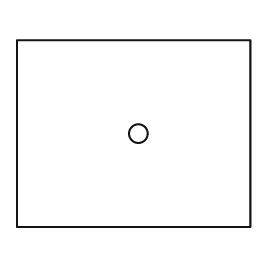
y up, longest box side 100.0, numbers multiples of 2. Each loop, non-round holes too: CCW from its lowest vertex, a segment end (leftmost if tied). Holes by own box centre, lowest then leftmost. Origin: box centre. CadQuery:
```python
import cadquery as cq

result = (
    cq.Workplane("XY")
    .moveTo(-50.0, -40.0)
    .lineTo(50.0, -40.0)
    .lineTo(50.0, 40.0)
    .lineTo(-50.0, 40.0)
    .close()
    .moveTo(2.0, 0.0)
    .circle(4.0)
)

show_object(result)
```